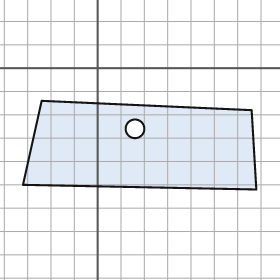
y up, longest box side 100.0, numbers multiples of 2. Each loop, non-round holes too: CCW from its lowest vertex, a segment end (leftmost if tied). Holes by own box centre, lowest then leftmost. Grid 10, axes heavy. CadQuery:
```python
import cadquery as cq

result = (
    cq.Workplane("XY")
    .moveTo(68.0, -52.0)
    .lineTo(66.0, -18.0)
    .lineTo(-24.0, -14.0)
    .lineTo(-32.0, -50.0)
    .close()
    .moveTo(16.0, -26.0)
    .circle(4.0)
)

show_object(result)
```